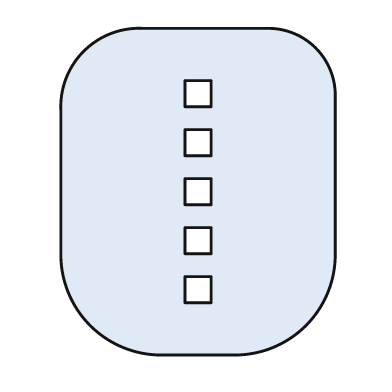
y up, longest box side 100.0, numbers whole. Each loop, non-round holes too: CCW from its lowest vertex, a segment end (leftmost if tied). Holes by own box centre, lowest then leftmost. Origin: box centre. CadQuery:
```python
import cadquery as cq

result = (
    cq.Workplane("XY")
    .moveTo(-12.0, -50.0)
    .lineTo(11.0, -50.0)
    .threePointArc((33.0, -41.0), (42.0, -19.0))
    .lineTo(42.0, 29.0)
    .threePointArc((36.0, 44.0), (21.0, 50.0))
    .lineTo(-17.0, 50.0)
    .threePointArc((-35.0, 43.0), (-42.0, 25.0))
    .lineTo(-42.0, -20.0)
    .threePointArc((-33.0, -41.0), (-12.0, -50.0))
    .close()
    .moveTo(-4.0, -34.0)
    .lineTo(4.0, -34.0)
    .lineTo(4.0, -26.0)
    .lineTo(-4.0, -26.0)
    .close()
    .moveTo(-4.0, -19.0)
    .lineTo(4.0, -19.0)
    .lineTo(4.0, -11.0)
    .lineTo(-4.0, -11.0)
    .close()
    .moveTo(-4.0, -4.0)
    .lineTo(4.0, -4.0)
    .lineTo(4.0, 4.0)
    .lineTo(-4.0, 4.0)
    .close()
    .moveTo(-4.0, 11.0)
    .lineTo(4.0, 11.0)
    .lineTo(4.0, 19.0)
    .lineTo(-4.0, 19.0)
    .close()
    .moveTo(-4.0, 26.0)
    .lineTo(4.0, 26.0)
    .lineTo(4.0, 34.0)
    .lineTo(-4.0, 34.0)
    .close()
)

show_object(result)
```